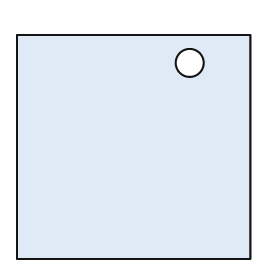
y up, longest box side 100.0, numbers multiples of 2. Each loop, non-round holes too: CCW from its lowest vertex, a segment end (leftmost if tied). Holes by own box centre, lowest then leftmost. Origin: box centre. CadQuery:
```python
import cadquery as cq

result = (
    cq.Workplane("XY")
    .moveTo(-50.0, -48.0)
    .lineTo(50.0, -48.0)
    .lineTo(50.0, 48.0)
    .lineTo(-50.0, 48.0)
    .close()
    .moveTo(24.0, 36.0)
    .circle(6.0)
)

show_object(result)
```